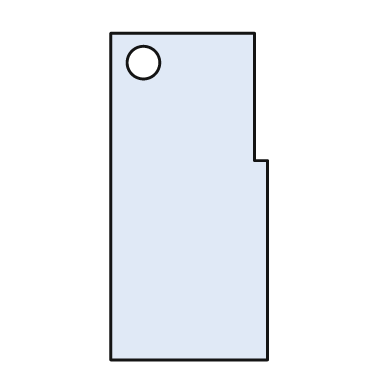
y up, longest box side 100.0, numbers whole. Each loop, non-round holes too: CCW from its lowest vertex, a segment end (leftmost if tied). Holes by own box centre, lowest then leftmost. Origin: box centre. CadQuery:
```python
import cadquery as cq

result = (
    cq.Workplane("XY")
    .moveTo(-24.0, -50.0)
    .lineTo(24.0, -50.0)
    .lineTo(24.0, 11.0)
    .lineTo(20.0, 11.0)
    .lineTo(20.0, 50.0)
    .lineTo(-24.0, 50.0)
    .close()
    .moveTo(-14.0, 41.0)
    .circle(5.0)
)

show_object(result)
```